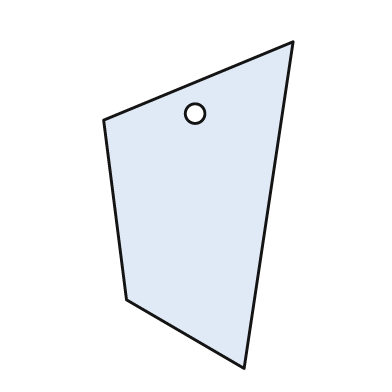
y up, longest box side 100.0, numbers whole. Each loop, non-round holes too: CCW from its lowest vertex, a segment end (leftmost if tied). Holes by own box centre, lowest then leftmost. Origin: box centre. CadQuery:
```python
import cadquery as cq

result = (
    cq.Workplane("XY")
    .moveTo(14.0, -50.0)
    .lineTo(29.0, 50.0)
    .lineTo(-29.0, 26.0)
    .lineTo(-22.0, -29.0)
    .close()
    .moveTo(-1.0, 28.0)
    .circle(3.0)
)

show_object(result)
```